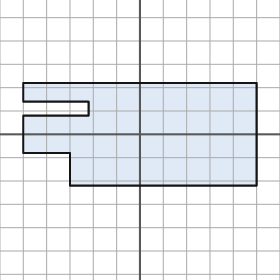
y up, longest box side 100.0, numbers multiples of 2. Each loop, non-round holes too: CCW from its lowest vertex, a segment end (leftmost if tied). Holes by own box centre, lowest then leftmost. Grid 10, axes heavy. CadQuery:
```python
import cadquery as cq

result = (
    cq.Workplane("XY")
    .moveTo(-30.0, -22.0)
    .lineTo(50.0, -22.0)
    .lineTo(50.0, 22.0)
    .lineTo(-50.0, 22.0)
    .lineTo(-50.0, 14.0)
    .lineTo(-22.0, 14.0)
    .lineTo(-22.0, 8.0)
    .lineTo(-50.0, 8.0)
    .lineTo(-50.0, -8.0)
    .lineTo(-30.0, -8.0)
    .close()
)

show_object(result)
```